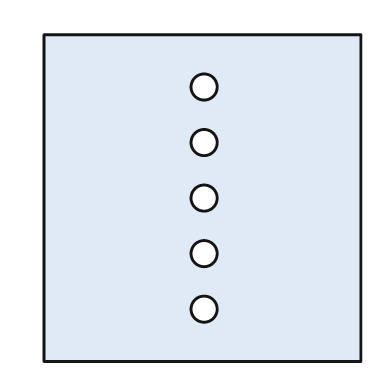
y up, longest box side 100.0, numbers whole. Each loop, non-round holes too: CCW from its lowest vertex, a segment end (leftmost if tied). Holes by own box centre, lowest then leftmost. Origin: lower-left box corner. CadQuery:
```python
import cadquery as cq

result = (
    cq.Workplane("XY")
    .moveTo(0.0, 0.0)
    .lineTo(97.0, 0.0)
    .lineTo(97.0, 100.0)
    .lineTo(0.0, 100.0)
    .close()
    .moveTo(49.0, 16.0)
    .circle(4.0)
    .moveTo(49.0, 33.0)
    .circle(4.0)
    .moveTo(49.0, 50.0)
    .circle(4.0)
    .moveTo(49.0, 67.0)
    .circle(4.0)
    .moveTo(49.0, 84.0)
    .circle(4.0)
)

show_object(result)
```